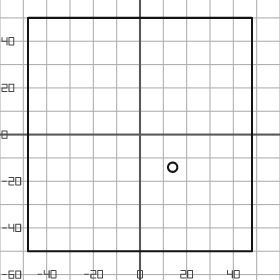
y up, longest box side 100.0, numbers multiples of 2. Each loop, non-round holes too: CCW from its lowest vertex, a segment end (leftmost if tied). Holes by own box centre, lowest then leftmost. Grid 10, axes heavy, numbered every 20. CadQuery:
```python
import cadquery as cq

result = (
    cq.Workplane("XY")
    .moveTo(-48.0, -50.0)
    .lineTo(48.0, -50.0)
    .lineTo(48.0, 50.0)
    .lineTo(-48.0, 50.0)
    .close()
    .moveTo(14.0, -14.0)
    .circle(2.0)
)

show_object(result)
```